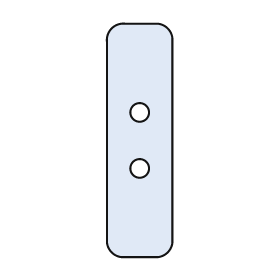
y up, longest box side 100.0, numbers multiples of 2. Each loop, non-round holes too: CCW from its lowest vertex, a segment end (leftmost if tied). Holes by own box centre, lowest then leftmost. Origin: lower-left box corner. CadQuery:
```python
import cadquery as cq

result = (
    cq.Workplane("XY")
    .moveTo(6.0, 0.0)
    .lineTo(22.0, 0.0)
    .threePointArc((26.0, 2.0), (28.0, 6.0))
    .lineTo(28.0, 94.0)
    .threePointArc((26.0, 98.0), (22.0, 100.0))
    .lineTo(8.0, 100.0)
    .threePointArc((2.0, 98.0), (0.0, 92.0))
    .lineTo(0.0, 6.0)
    .threePointArc((2.0, 2.0), (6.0, 0.0))
    .close()
    .moveTo(14.0, 38.0)
    .circle(4.0)
    .moveTo(14.0, 62.0)
    .circle(4.0)
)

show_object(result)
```